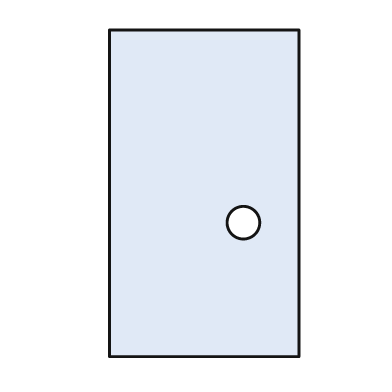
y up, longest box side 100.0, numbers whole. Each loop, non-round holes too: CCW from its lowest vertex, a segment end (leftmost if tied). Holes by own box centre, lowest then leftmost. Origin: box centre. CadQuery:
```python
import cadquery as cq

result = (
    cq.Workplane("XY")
    .moveTo(-29.0, -50.0)
    .lineTo(29.0, -50.0)
    .lineTo(29.0, 50.0)
    .lineTo(-29.0, 50.0)
    .close()
    .moveTo(12.0, -9.0)
    .circle(5.0)
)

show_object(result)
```